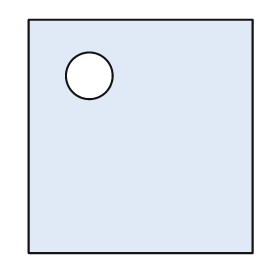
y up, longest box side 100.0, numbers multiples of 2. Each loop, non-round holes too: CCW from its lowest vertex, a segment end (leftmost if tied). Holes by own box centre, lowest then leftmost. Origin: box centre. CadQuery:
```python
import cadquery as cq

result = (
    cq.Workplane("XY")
    .moveTo(-48.0, -50.0)
    .lineTo(48.0, -50.0)
    .lineTo(48.0, 50.0)
    .lineTo(-48.0, 50.0)
    .close()
    .moveTo(-22.0, 26.0)
    .circle(10.0)
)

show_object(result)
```